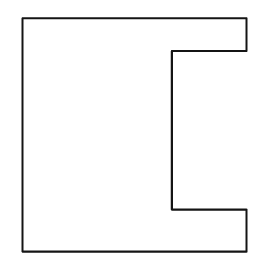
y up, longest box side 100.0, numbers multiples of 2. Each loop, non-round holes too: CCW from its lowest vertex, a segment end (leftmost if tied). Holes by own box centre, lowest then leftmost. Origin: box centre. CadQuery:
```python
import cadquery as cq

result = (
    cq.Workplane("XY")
    .moveTo(-48.0, -50.0)
    .lineTo(48.0, -50.0)
    .lineTo(48.0, -32.0)
    .lineTo(16.0, -32.0)
    .lineTo(16.0, 36.0)
    .lineTo(48.0, 36.0)
    .lineTo(48.0, 50.0)
    .lineTo(-48.0, 50.0)
    .close()
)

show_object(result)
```